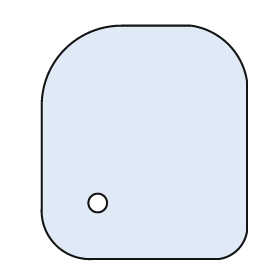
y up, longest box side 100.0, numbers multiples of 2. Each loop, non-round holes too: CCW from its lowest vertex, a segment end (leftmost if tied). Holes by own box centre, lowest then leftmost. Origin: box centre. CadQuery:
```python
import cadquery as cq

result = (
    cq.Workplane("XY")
    .moveTo(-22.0, -50.0)
    .lineTo(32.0, -50.0)
    .threePointArc((40.0, -46.0), (44.0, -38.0))
    .lineTo(44.0, 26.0)
    .threePointArc((36.0, 42.0), (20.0, 50.0))
    .lineTo(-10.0, 50.0)
    .threePointArc((-34.0, 40.0), (-44.0, 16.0))
    .lineTo(-44.0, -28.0)
    .threePointArc((-38.0, -44.0), (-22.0, -50.0))
    .close()
    .moveTo(-20.0, -26.0)
    .circle(4.0)
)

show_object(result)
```